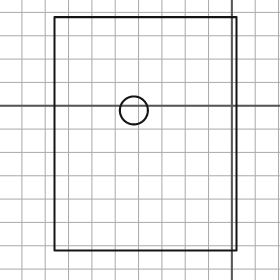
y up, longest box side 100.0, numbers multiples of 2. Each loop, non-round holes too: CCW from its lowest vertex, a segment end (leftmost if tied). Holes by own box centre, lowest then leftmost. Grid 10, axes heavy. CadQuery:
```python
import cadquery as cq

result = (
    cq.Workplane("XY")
    .moveTo(-76.0, -62.0)
    .lineTo(2.0, -62.0)
    .lineTo(2.0, 38.0)
    .lineTo(-76.0, 38.0)
    .close()
    .moveTo(-42.0, -2.0)
    .circle(6.0)
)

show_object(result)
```